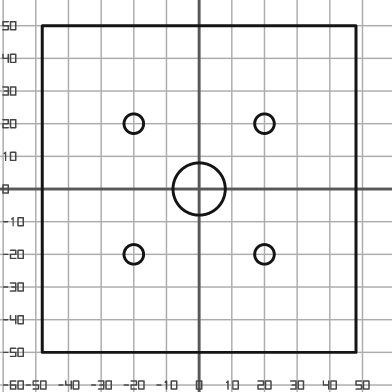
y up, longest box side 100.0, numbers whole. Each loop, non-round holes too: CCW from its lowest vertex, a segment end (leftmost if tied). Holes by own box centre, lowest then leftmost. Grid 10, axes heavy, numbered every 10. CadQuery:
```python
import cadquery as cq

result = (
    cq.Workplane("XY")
    .moveTo(-48.0, -50.0)
    .lineTo(48.0, -50.0)
    .lineTo(48.0, 50.0)
    .lineTo(-48.0, 50.0)
    .close()
    .moveTo(-20.0, -20.0)
    .circle(3.0)
    .moveTo(20.0, -20.0)
    .circle(3.0)
    .moveTo(0.0, 0.0)
    .circle(8.0)
    .moveTo(-20.0, 20.0)
    .circle(3.0)
    .moveTo(20.0, 20.0)
    .circle(3.0)
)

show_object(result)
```